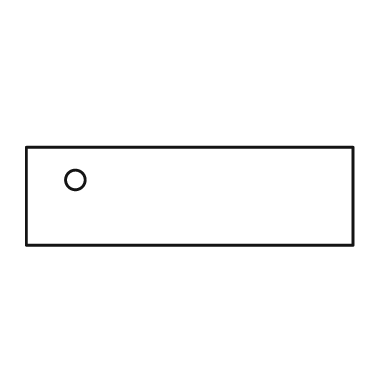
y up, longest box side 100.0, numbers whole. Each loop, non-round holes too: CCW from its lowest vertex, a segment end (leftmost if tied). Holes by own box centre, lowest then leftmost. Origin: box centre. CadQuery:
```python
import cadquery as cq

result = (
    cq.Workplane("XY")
    .moveTo(-50.0, -15.0)
    .lineTo(50.0, -15.0)
    .lineTo(50.0, 15.0)
    .lineTo(-50.0, 15.0)
    .close()
    .moveTo(-35.0, 5.0)
    .circle(3.0)
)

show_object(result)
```